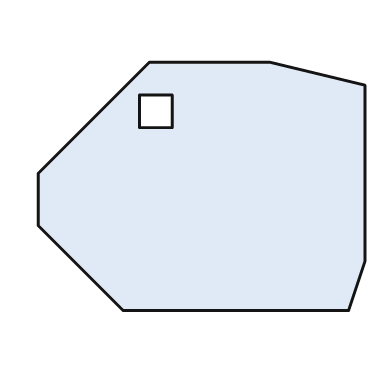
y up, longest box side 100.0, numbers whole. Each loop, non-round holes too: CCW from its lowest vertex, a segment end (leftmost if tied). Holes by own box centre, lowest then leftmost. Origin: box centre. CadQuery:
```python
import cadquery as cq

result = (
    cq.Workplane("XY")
    .moveTo(-24.0, -38.0)
    .lineTo(45.0, -38.0)
    .lineTo(50.0, -23.0)
    .lineTo(50.0, 31.0)
    .lineTo(21.0, 38.0)
    .lineTo(-16.0, 38.0)
    .lineTo(-50.0, 4.0)
    .lineTo(-50.0, -12.0)
    .close()
    .moveTo(-19.0, 18.0)
    .lineTo(-9.0, 18.0)
    .lineTo(-9.0, 28.0)
    .lineTo(-19.0, 28.0)
    .close()
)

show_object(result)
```